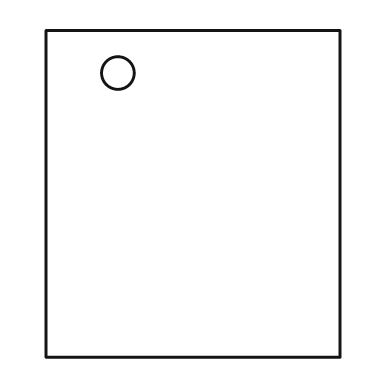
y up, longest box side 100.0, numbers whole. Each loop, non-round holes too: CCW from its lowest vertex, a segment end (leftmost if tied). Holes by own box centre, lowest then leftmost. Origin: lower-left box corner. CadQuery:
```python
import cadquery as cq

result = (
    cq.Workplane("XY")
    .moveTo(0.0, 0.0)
    .lineTo(90.0, 0.0)
    .lineTo(90.0, 100.0)
    .lineTo(0.0, 100.0)
    .close()
    .moveTo(22.0, 87.0)
    .circle(5.0)
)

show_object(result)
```